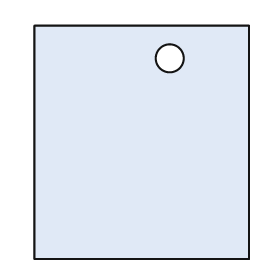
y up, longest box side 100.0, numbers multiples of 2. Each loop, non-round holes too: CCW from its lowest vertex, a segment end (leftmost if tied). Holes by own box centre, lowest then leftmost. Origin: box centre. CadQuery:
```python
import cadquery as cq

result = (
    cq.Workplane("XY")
    .moveTo(-46.0, -50.0)
    .lineTo(46.0, -50.0)
    .lineTo(46.0, 50.0)
    .lineTo(-46.0, 50.0)
    .close()
    .moveTo(12.0, 36.0)
    .circle(6.0)
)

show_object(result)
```